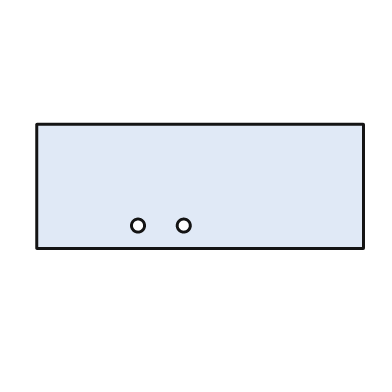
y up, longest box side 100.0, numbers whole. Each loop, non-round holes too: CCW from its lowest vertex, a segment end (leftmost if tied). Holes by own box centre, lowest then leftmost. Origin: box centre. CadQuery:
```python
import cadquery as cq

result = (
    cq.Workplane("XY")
    .moveTo(-50.0, -19.0)
    .lineTo(50.0, -19.0)
    .lineTo(50.0, 19.0)
    .lineTo(-50.0, 19.0)
    .close()
    .moveTo(-19.0, -12.0)
    .circle(2.0)
    .moveTo(-5.0, -12.0)
    .circle(2.0)
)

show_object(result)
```